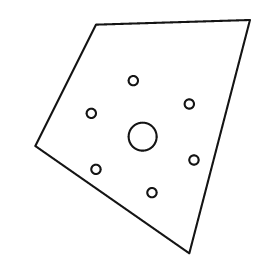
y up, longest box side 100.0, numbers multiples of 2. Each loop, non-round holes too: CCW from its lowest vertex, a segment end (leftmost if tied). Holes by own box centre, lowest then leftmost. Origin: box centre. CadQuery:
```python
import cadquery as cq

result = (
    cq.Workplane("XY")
    .moveTo(20.0, -50.0)
    .lineTo(46.0, 50.0)
    .lineTo(-20.0, 48.0)
    .lineTo(-46.0, -4.0)
    .close()
    .moveTo(4.0, -24.0)
    .circle(2.0)
    .moveTo(-20.0, -14.0)
    .circle(2.0)
    .moveTo(22.0, -10.0)
    .circle(2.0)
    .moveTo(0.0, 0.0)
    .circle(6.0)
    .moveTo(-22.0, 10.0)
    .circle(2.0)
    .moveTo(20.0, 14.0)
    .circle(2.0)
    .moveTo(-4.0, 24.0)
    .circle(2.0)
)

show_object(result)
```